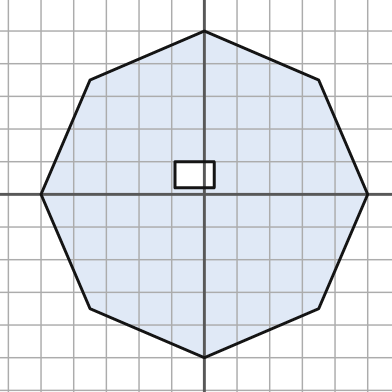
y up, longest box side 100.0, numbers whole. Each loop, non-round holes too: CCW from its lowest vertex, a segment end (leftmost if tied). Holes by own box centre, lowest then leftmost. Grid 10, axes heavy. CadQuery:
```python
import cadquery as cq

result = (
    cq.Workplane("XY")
    .moveTo(0.0, -50.0)
    .lineTo(35.0, -35.0)
    .lineTo(50.0, 0.0)
    .lineTo(35.0, 35.0)
    .lineTo(0.0, 50.0)
    .lineTo(-35.0, 35.0)
    .lineTo(-50.0, 0.0)
    .lineTo(-35.0, -35.0)
    .close()
    .moveTo(-9.0, 2.0)
    .lineTo(3.0, 2.0)
    .lineTo(3.0, 10.0)
    .lineTo(-9.0, 10.0)
    .close()
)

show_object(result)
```